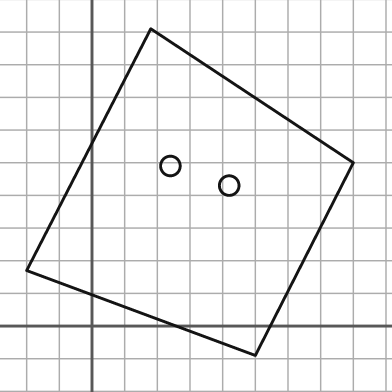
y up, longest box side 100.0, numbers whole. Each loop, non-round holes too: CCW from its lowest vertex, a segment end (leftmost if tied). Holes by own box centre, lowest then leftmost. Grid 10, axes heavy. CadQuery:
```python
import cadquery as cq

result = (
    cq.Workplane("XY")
    .moveTo(50.0, -9.0)
    .lineTo(80.0, 50.0)
    .lineTo(18.0, 91.0)
    .lineTo(-20.0, 17.0)
    .close()
    .moveTo(42.0, 43.0)
    .circle(3.0)
    .moveTo(24.0, 49.0)
    .circle(3.0)
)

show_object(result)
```